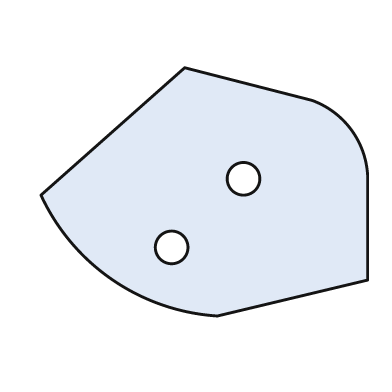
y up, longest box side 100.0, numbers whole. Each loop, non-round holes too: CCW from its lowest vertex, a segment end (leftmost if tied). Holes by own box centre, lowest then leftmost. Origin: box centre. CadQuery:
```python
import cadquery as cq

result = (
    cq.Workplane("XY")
    .moveTo(4.0, -38.0)
    .lineTo(50.0, -27.0)
    .lineTo(50.0, 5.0)
    .threePointArc((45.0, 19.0), (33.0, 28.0))
    .lineTo(-6.0, 38.0)
    .lineTo(-50.0, -1.0)
    .threePointArc((-28.0, -27.0), (4.0, -38.0))
    .close()
    .moveTo(-10.0, -17.0)
    .circle(5.0)
    .moveTo(12.0, 4.0)
    .circle(5.0)
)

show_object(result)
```